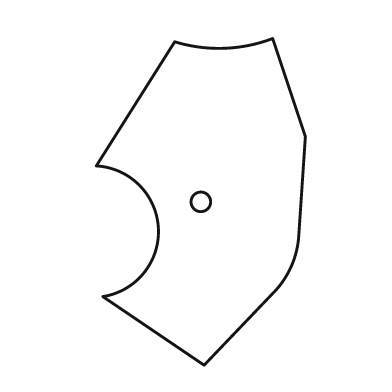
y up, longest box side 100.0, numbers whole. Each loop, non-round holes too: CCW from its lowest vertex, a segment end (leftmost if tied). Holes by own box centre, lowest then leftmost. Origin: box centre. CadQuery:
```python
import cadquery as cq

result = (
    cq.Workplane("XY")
    .moveTo(1.0, -50.0)
    .lineTo(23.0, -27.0)
    .threePointArc((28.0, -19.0), (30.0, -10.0))
    .lineTo(32.0, 20.0)
    .lineTo(22.0, 50.0)
    .threePointArc((7.0, 47.0), (-8.0, 49.0))
    .lineTo(-32.0, 11.0)
    .threePointArc((-13.0, -8.0), (-30.0, -29.0))
    .close()
    .moveTo(0.0, 0.0)
    .circle(3.0)
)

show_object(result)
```